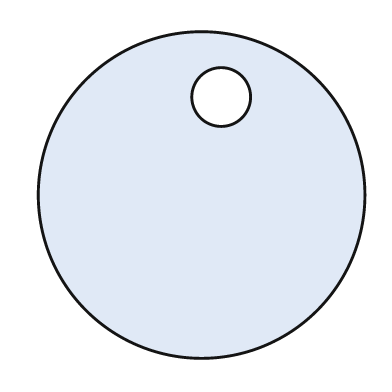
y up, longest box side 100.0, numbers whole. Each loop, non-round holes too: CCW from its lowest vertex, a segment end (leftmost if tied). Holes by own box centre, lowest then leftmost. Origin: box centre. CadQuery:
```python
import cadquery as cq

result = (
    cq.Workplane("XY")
    .moveTo(0.0, 0.0)
    .circle(50.0)
    .moveTo(6.0, 30.0)
    .circle(9.0)
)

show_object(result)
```